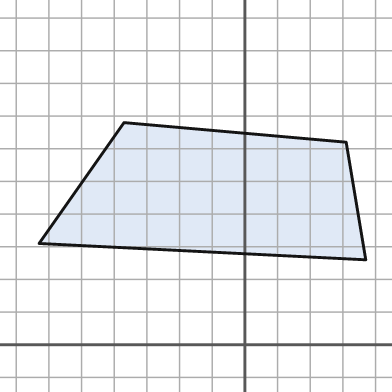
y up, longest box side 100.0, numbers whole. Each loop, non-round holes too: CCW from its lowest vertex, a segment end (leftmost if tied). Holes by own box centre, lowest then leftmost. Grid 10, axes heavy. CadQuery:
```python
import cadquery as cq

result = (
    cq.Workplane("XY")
    .moveTo(37.0, 26.0)
    .lineTo(31.0, 62.0)
    .lineTo(-37.0, 68.0)
    .lineTo(-63.0, 31.0)
    .close()
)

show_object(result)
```